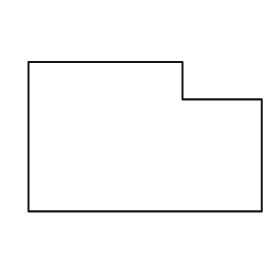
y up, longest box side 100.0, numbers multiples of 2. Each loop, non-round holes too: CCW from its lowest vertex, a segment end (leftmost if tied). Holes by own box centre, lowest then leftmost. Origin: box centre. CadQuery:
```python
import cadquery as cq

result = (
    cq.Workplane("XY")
    .moveTo(-50.0, -32.0)
    .lineTo(50.0, -32.0)
    .lineTo(50.0, 16.0)
    .lineTo(16.0, 16.0)
    .lineTo(16.0, 32.0)
    .lineTo(-50.0, 32.0)
    .close()
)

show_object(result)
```